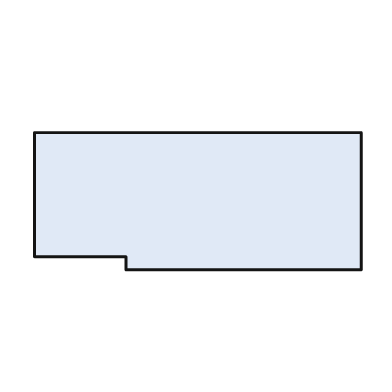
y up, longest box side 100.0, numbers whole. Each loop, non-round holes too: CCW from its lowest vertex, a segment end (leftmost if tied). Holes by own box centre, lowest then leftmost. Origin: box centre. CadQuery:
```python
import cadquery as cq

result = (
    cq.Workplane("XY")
    .moveTo(-22.0, -21.0)
    .lineTo(50.0, -21.0)
    .lineTo(50.0, 21.0)
    .lineTo(-50.0, 21.0)
    .lineTo(-50.0, -17.0)
    .lineTo(-22.0, -17.0)
    .close()
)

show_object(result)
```